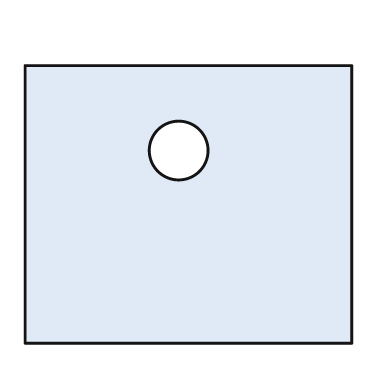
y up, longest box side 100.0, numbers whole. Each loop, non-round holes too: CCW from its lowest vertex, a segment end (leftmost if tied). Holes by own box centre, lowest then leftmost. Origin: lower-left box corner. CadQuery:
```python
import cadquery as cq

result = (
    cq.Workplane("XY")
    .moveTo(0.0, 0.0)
    .lineTo(100.0, 0.0)
    .lineTo(100.0, 85.0)
    .lineTo(0.0, 85.0)
    .close()
    .moveTo(47.0, 59.0)
    .circle(9.0)
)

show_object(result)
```